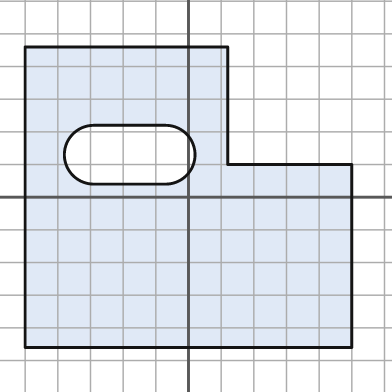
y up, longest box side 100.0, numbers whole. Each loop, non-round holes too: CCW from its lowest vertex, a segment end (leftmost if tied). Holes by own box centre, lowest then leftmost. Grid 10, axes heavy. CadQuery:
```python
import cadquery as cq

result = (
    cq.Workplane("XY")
    .moveTo(-50.0, -46.0)
    .lineTo(50.0, -46.0)
    .lineTo(50.0, 10.0)
    .lineTo(12.0, 10.0)
    .lineTo(12.0, 46.0)
    .lineTo(-50.0, 46.0)
    .close()
    .moveTo(-29.0, 4.0)
    .lineTo(-7.0, 4.0)
    .threePointArc((2.0, 13.0), (-7.0, 22.0))
    .lineTo(-29.0, 22.0)
    .threePointArc((-38.0, 13.0), (-29.0, 4.0))
    .close()
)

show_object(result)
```